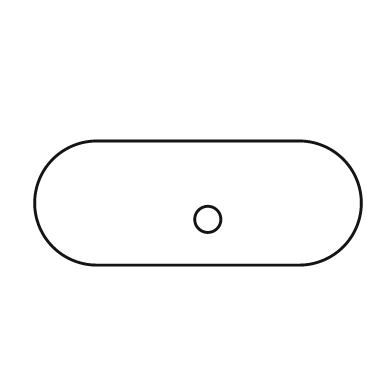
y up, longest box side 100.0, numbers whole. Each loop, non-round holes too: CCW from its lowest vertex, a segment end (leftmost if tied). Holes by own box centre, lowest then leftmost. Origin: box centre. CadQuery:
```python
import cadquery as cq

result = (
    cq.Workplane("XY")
    .moveTo(-31.0, -19.0)
    .lineTo(31.0, -19.0)
    .threePointArc((50.0, 0.0), (31.0, 19.0))
    .lineTo(-31.0, 19.0)
    .threePointArc((-50.0, 0.0), (-31.0, -19.0))
    .close()
    .moveTo(3.0, -5.0)
    .circle(4.0)
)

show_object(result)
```